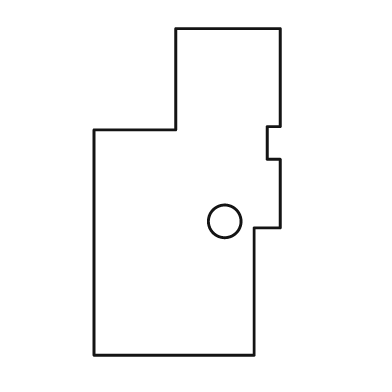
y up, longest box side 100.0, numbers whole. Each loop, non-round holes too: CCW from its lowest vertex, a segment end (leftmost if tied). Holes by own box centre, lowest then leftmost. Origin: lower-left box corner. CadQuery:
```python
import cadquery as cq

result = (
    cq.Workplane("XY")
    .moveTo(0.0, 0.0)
    .lineTo(49.0, 0.0)
    .lineTo(49.0, 39.0)
    .lineTo(57.0, 39.0)
    .lineTo(57.0, 60.0)
    .lineTo(53.0, 60.0)
    .lineTo(53.0, 70.0)
    .lineTo(57.0, 70.0)
    .lineTo(57.0, 100.0)
    .lineTo(25.0, 100.0)
    .lineTo(25.0, 69.0)
    .lineTo(0.0, 69.0)
    .close()
    .moveTo(40.0, 41.0)
    .circle(5.0)
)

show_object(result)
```